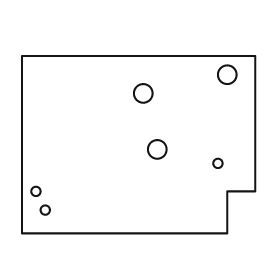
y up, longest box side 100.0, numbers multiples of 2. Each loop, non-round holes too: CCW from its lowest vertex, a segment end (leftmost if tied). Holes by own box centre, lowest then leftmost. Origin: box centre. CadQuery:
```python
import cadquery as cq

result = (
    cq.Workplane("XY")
    .moveTo(-50.0, -38.0)
    .lineTo(38.0, -38.0)
    .lineTo(38.0, -20.0)
    .lineTo(50.0, -20.0)
    .lineTo(50.0, 38.0)
    .lineTo(-50.0, 38.0)
    .close()
    .moveTo(-40.0, -28.0)
    .circle(2.0)
    .moveTo(-44.0, -20.0)
    .circle(2.0)
    .moveTo(34.0, -8.0)
    .circle(2.0)
    .moveTo(8.0, -2.0)
    .circle(4.0)
    .moveTo(2.0, 22.0)
    .circle(4.0)
    .moveTo(38.0, 30.0)
    .circle(4.0)
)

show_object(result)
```